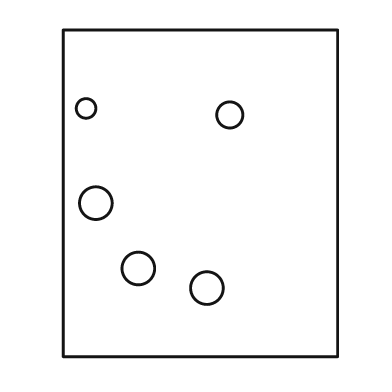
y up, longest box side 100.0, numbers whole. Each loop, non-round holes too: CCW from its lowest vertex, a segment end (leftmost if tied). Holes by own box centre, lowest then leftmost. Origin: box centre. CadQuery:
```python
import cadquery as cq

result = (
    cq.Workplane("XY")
    .moveTo(-42.0, -50.0)
    .lineTo(42.0, -50.0)
    .lineTo(42.0, 50.0)
    .lineTo(-42.0, 50.0)
    .close()
    .moveTo(2.0, -29.0)
    .circle(5.0)
    .moveTo(-19.0, -23.0)
    .circle(5.0)
    .moveTo(-32.0, -3.0)
    .circle(5.0)
    .moveTo(9.0, 24.0)
    .circle(4.0)
    .moveTo(-35.0, 26.0)
    .circle(3.0)
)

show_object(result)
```